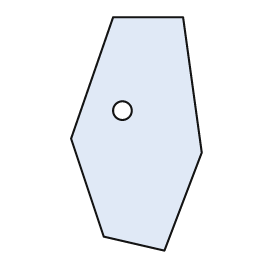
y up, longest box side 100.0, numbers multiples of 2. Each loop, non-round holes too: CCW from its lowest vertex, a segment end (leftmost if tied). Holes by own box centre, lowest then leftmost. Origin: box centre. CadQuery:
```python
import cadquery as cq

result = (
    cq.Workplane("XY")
    .moveTo(12.0, -50.0)
    .lineTo(28.0, -8.0)
    .lineTo(20.0, 50.0)
    .lineTo(-10.0, 50.0)
    .lineTo(-28.0, -2.0)
    .lineTo(-14.0, -44.0)
    .close()
    .moveTo(-6.0, 10.0)
    .circle(4.0)
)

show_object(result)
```